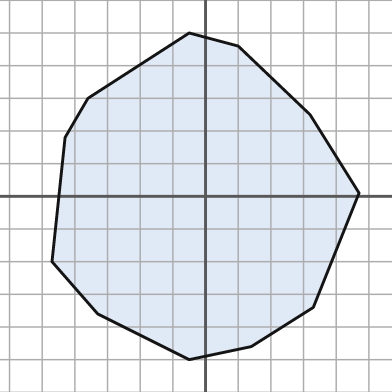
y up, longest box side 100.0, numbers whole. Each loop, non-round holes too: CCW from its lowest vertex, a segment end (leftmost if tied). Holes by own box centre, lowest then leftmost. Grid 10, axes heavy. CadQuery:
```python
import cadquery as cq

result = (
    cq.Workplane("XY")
    .moveTo(-5.0, -50.0)
    .lineTo(14.0, -46.0)
    .lineTo(33.0, -34.0)
    .lineTo(47.0, 1.0)
    .lineTo(32.0, 25.0)
    .lineTo(10.0, 46.0)
    .lineTo(-5.0, 50.0)
    .lineTo(-36.0, 30.0)
    .lineTo(-43.0, 18.0)
    .lineTo(-47.0, -20.0)
    .lineTo(-33.0, -36.0)
    .close()
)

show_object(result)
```